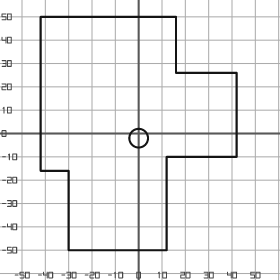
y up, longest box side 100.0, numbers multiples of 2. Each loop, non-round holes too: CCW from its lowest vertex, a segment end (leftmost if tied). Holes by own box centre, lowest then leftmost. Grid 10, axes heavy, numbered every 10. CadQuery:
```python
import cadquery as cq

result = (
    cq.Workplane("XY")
    .moveTo(-30.0, -50.0)
    .lineTo(12.0, -50.0)
    .lineTo(12.0, -10.0)
    .lineTo(42.0, -10.0)
    .lineTo(42.0, 26.0)
    .lineTo(16.0, 26.0)
    .lineTo(16.0, 50.0)
    .lineTo(-42.0, 50.0)
    .lineTo(-42.0, -16.0)
    .lineTo(-30.0, -16.0)
    .close()
    .moveTo(0.0, -2.0)
    .circle(4.0)
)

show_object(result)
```